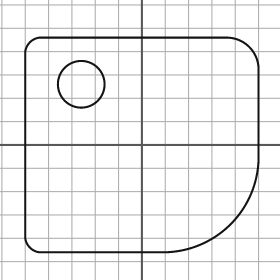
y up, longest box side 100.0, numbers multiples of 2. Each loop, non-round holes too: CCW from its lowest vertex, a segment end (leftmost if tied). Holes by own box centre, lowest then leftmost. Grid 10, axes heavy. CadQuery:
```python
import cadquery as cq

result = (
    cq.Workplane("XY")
    .moveTo(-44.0, -46.0)
    .lineTo(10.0, -46.0)
    .threePointArc((38.0, -34.0), (50.0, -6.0))
    .lineTo(50.0, 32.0)
    .threePointArc((46.0, 42.0), (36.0, 46.0))
    .lineTo(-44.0, 46.0)
    .threePointArc((-48.0, 44.0), (-50.0, 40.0))
    .lineTo(-50.0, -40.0)
    .threePointArc((-48.0, -44.0), (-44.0, -46.0))
    .close()
    .moveTo(-26.0, 26.0)
    .circle(10.0)
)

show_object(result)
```